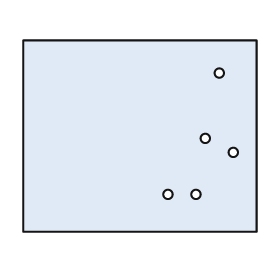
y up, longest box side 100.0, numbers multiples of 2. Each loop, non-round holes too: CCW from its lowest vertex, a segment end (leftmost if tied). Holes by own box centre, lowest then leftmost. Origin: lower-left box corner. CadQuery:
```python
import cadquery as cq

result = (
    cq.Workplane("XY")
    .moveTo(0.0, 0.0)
    .lineTo(100.0, 0.0)
    .lineTo(100.0, 82.0)
    .lineTo(0.0, 82.0)
    .close()
    .moveTo(62.0, 16.0)
    .circle(2.0)
    .moveTo(74.0, 16.0)
    .circle(2.0)
    .moveTo(90.0, 34.0)
    .circle(2.0)
    .moveTo(78.0, 40.0)
    .circle(2.0)
    .moveTo(84.0, 68.0)
    .circle(2.0)
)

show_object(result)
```